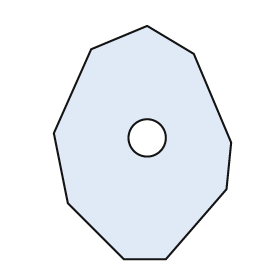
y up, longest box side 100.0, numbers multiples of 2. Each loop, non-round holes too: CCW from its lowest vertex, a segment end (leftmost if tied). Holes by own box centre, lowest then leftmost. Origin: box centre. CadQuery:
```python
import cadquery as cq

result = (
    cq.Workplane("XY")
    .moveTo(-8.0, -50.0)
    .lineTo(10.0, -50.0)
    .lineTo(36.0, -20.0)
    .lineTo(38.0, 0.0)
    .lineTo(22.0, 38.0)
    .lineTo(2.0, 50.0)
    .lineTo(-22.0, 40.0)
    .lineTo(-38.0, 4.0)
    .lineTo(-32.0, -26.0)
    .close()
    .moveTo(2.0, 2.0)
    .circle(8.0)
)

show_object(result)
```